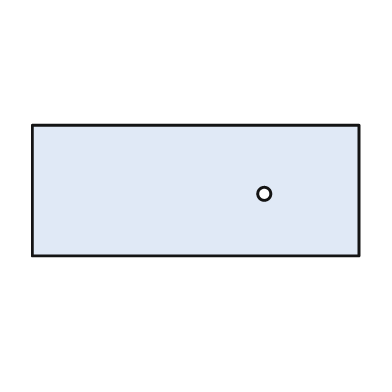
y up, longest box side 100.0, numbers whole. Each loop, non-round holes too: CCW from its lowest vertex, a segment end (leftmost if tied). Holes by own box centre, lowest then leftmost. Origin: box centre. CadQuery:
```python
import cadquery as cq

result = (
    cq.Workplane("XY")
    .moveTo(-50.0, -20.0)
    .lineTo(50.0, -20.0)
    .lineTo(50.0, 20.0)
    .lineTo(-50.0, 20.0)
    .close()
    .moveTo(21.0, -1.0)
    .circle(2.0)
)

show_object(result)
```